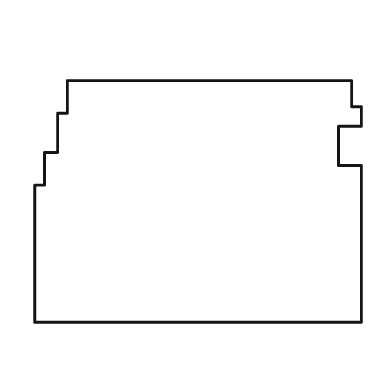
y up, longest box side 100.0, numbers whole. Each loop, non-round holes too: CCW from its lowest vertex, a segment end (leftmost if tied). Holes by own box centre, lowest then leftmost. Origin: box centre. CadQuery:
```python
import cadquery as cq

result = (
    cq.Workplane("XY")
    .moveTo(-50.0, -37.0)
    .lineTo(50.0, -37.0)
    .lineTo(50.0, 11.0)
    .lineTo(43.0, 11.0)
    .lineTo(43.0, 23.0)
    .lineTo(50.0, 23.0)
    .lineTo(50.0, 29.0)
    .lineTo(47.0, 29.0)
    .lineTo(47.0, 37.0)
    .lineTo(-40.0, 37.0)
    .lineTo(-40.0, 27.0)
    .lineTo(-43.0, 27.0)
    .lineTo(-43.0, 15.0)
    .lineTo(-47.0, 15.0)
    .lineTo(-47.0, 5.0)
    .lineTo(-50.0, 5.0)
    .close()
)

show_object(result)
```